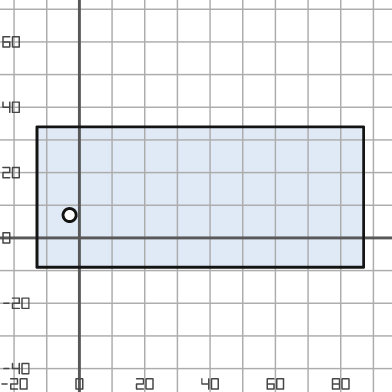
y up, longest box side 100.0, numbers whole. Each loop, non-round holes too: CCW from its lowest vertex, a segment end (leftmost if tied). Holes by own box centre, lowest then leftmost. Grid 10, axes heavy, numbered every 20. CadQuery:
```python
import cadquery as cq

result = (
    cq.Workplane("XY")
    .moveTo(-13.0, -9.0)
    .lineTo(87.0, -9.0)
    .lineTo(87.0, 34.0)
    .lineTo(-13.0, 34.0)
    .close()
    .moveTo(-3.0, 7.0)
    .circle(2.0)
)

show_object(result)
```